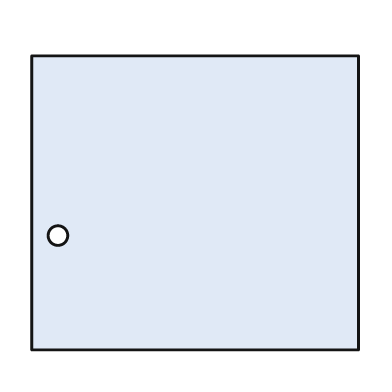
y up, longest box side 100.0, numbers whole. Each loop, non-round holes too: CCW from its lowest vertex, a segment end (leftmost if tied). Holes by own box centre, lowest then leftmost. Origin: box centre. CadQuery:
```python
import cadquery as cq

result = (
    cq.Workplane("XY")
    .moveTo(-50.0, -45.0)
    .lineTo(50.0, -45.0)
    .lineTo(50.0, 45.0)
    .lineTo(-50.0, 45.0)
    .close()
    .moveTo(-42.0, -10.0)
    .circle(3.0)
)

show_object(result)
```